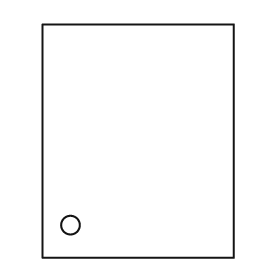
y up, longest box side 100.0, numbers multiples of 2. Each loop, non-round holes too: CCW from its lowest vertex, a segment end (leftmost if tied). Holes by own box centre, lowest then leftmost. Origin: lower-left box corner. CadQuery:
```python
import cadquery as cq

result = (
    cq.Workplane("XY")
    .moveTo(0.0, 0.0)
    .lineTo(82.0, 0.0)
    .lineTo(82.0, 100.0)
    .lineTo(0.0, 100.0)
    .close()
    .moveTo(12.0, 14.0)
    .circle(4.0)
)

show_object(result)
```